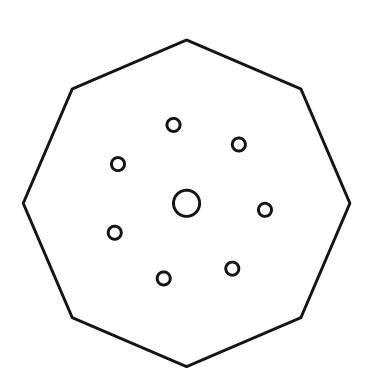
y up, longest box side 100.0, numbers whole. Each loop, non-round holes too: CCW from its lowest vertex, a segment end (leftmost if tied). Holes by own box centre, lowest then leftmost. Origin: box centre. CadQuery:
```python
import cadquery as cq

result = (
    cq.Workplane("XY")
    .moveTo(0.0, -50.0)
    .lineTo(35.0, -35.0)
    .lineTo(50.0, 0.0)
    .lineTo(35.0, 35.0)
    .lineTo(0.0, 50.0)
    .lineTo(-35.0, 35.0)
    .lineTo(-50.0, 0.0)
    .lineTo(-35.0, -35.0)
    .close()
    .moveTo(-7.0, -23.0)
    .circle(2.0)
    .moveTo(14.0, -20.0)
    .circle(2.0)
    .moveTo(-22.0, -9.0)
    .circle(2.0)
    .moveTo(24.0, -2.0)
    .circle(2.0)
    .moveTo(0.0, 0.0)
    .circle(4.0)
    .moveTo(-21.0, 12.0)
    .circle(2.0)
    .moveTo(16.0, 18.0)
    .circle(2.0)
    .moveTo(-4.0, 24.0)
    .circle(2.0)
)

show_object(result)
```